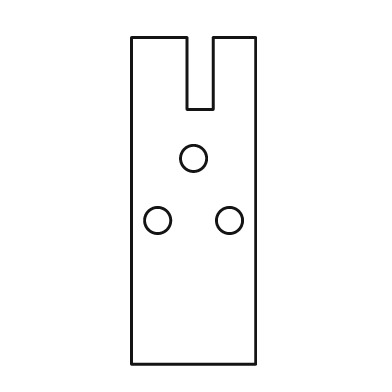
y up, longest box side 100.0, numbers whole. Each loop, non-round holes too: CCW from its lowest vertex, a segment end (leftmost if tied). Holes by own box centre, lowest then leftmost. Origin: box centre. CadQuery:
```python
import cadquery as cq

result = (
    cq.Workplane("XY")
    .moveTo(-19.0, -50.0)
    .lineTo(19.0, -50.0)
    .lineTo(19.0, 50.0)
    .lineTo(6.0, 50.0)
    .lineTo(6.0, 28.0)
    .lineTo(-2.0, 28.0)
    .lineTo(-2.0, 50.0)
    .lineTo(-19.0, 50.0)
    .close()
    .moveTo(-11.0, -6.0)
    .circle(4.0)
    .moveTo(11.0, -6.0)
    .circle(4.0)
    .moveTo(0.0, 13.0)
    .circle(4.0)
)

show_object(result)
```